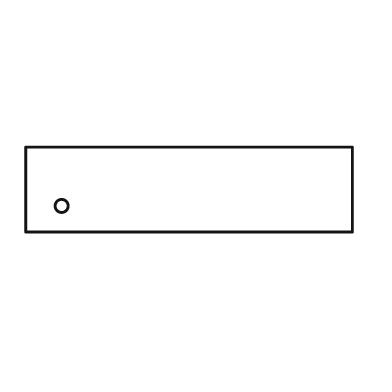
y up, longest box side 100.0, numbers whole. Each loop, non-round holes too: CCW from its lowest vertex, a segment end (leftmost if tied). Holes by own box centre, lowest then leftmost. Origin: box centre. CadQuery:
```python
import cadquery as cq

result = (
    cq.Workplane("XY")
    .moveTo(-50.0, -13.0)
    .lineTo(50.0, -13.0)
    .lineTo(50.0, 13.0)
    .lineTo(-50.0, 13.0)
    .close()
    .moveTo(-39.0, -5.0)
    .circle(2.0)
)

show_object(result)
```